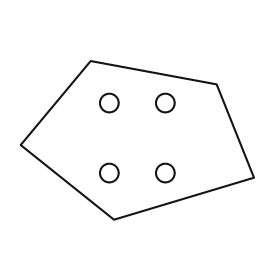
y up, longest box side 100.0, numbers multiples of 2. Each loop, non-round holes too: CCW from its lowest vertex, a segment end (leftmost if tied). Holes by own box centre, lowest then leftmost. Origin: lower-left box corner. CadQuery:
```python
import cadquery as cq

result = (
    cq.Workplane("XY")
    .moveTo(40.0, 0.0)
    .lineTo(100.0, 18.0)
    .lineTo(84.0, 58.0)
    .lineTo(30.0, 68.0)
    .lineTo(0.0, 32.0)
    .close()
    .moveTo(38.0, 20.0)
    .circle(4.0)
    .moveTo(62.0, 20.0)
    .circle(4.0)
    .moveTo(38.0, 50.0)
    .circle(4.0)
    .moveTo(62.0, 50.0)
    .circle(4.0)
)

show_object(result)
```